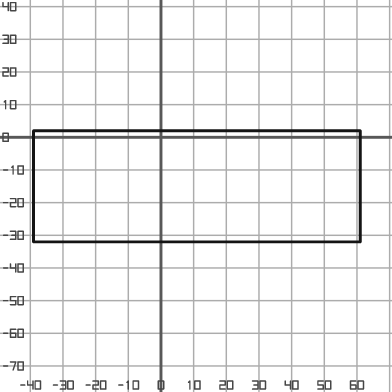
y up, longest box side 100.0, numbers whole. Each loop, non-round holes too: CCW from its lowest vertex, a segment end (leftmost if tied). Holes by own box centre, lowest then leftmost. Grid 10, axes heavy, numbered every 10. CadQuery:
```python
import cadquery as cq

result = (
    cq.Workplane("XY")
    .moveTo(-39.0, -32.0)
    .lineTo(61.0, -32.0)
    .lineTo(61.0, 2.0)
    .lineTo(-39.0, 2.0)
    .close()
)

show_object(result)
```